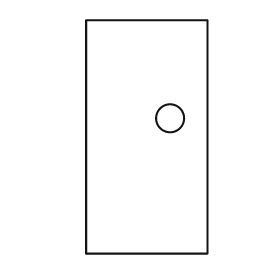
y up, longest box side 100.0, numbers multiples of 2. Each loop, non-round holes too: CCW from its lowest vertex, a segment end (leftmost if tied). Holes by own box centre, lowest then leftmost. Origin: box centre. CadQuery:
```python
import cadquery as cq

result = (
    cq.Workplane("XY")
    .moveTo(-26.0, -50.0)
    .lineTo(26.0, -50.0)
    .lineTo(26.0, 50.0)
    .lineTo(-26.0, 50.0)
    .close()
    .moveTo(10.0, 8.0)
    .circle(6.0)
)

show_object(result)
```